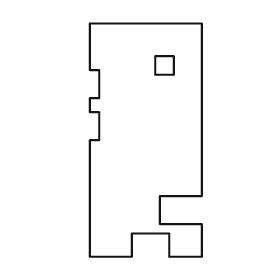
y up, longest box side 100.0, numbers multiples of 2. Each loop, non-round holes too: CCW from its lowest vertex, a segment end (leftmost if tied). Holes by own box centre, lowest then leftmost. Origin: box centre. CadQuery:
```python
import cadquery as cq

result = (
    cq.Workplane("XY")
    .moveTo(-24.0, -50.0)
    .lineTo(-6.0, -50.0)
    .lineTo(-6.0, -40.0)
    .lineTo(10.0, -40.0)
    .lineTo(10.0, -50.0)
    .lineTo(24.0, -50.0)
    .lineTo(24.0, -36.0)
    .lineTo(6.0, -36.0)
    .lineTo(6.0, -24.0)
    .lineTo(24.0, -24.0)
    .lineTo(24.0, 50.0)
    .lineTo(-24.0, 50.0)
    .lineTo(-24.0, 30.0)
    .lineTo(-20.0, 30.0)
    .lineTo(-20.0, 18.0)
    .lineTo(-24.0, 18.0)
    .lineTo(-24.0, 12.0)
    .lineTo(-20.0, 12.0)
    .lineTo(-20.0, 0.0)
    .lineTo(-24.0, 0.0)
    .close()
    .moveTo(4.0, 28.0)
    .lineTo(12.0, 28.0)
    .lineTo(12.0, 36.0)
    .lineTo(4.0, 36.0)
    .close()
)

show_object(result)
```